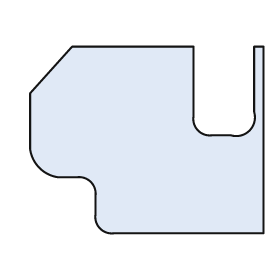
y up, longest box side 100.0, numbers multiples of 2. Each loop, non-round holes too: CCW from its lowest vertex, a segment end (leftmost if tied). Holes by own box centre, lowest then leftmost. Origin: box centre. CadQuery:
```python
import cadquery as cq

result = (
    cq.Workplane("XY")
    .moveTo(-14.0, -40.0)
    .lineTo(50.0, -40.0)
    .lineTo(50.0, 40.0)
    .lineTo(46.0, 40.0)
    .lineTo(46.0, 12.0)
    .threePointArc((44.0, 4.0), (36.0, 2.0))
    .lineTo(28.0, 2.0)
    .threePointArc((22.0, 4.0), (20.0, 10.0))
    .lineTo(20.0, 40.0)
    .lineTo(-32.0, 40.0)
    .lineTo(-50.0, 20.0)
    .lineTo(-50.0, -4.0)
    .threePointArc((-46.0, -12.0), (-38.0, -16.0))
    .lineTo(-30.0, -16.0)
    .threePointArc((-24.0, -18.0), (-22.0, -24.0))
    .lineTo(-22.0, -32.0)
    .threePointArc((-20.0, -38.0), (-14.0, -40.0))
    .close()
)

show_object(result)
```